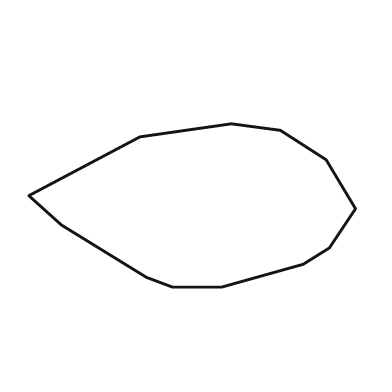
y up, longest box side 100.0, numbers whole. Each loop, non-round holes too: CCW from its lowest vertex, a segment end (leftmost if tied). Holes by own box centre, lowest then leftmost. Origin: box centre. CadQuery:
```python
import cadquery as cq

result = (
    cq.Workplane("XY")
    .moveTo(-6.0, -25.0)
    .lineTo(9.0, -25.0)
    .lineTo(34.0, -18.0)
    .lineTo(42.0, -13.0)
    .lineTo(50.0, -1.0)
    .lineTo(41.0, 14.0)
    .lineTo(27.0, 23.0)
    .lineTo(12.0, 25.0)
    .lineTo(-16.0, 21.0)
    .lineTo(-50.0, 3.0)
    .lineTo(-40.0, -6.0)
    .lineTo(-14.0, -22.0)
    .close()
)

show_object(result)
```